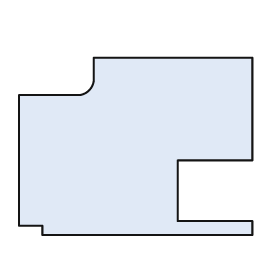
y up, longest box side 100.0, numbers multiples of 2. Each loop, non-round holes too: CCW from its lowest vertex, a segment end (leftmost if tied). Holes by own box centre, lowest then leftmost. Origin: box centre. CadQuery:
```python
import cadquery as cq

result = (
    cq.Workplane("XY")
    .moveTo(-40.0, -38.0)
    .lineTo(50.0, -38.0)
    .lineTo(50.0, -32.0)
    .lineTo(18.0, -32.0)
    .lineTo(18.0, -6.0)
    .lineTo(50.0, -6.0)
    .lineTo(50.0, 38.0)
    .lineTo(-18.0, 38.0)
    .lineTo(-18.0, 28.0)
    .threePointArc((-20.0, 24.0), (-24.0, 22.0))
    .lineTo(-50.0, 22.0)
    .lineTo(-50.0, -34.0)
    .lineTo(-40.0, -34.0)
    .close()
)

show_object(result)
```